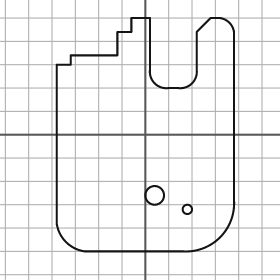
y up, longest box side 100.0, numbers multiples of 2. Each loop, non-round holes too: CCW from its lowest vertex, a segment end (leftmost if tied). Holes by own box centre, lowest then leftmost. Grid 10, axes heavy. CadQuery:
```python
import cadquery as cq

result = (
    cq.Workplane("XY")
    .moveTo(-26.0, -50.0)
    .lineTo(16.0, -50.0)
    .threePointArc((32.0, -44.0), (38.0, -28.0))
    .lineTo(38.0, 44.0)
    .threePointArc((36.0, 48.0), (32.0, 50.0))
    .lineTo(28.0, 50.0)
    .lineTo(22.0, 44.0)
    .lineTo(22.0, 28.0)
    .threePointArc((20.0, 22.0), (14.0, 20.0))
    .lineTo(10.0, 20.0)
    .threePointArc((4.0, 22.0), (2.0, 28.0))
    .lineTo(2.0, 50.0)
    .lineTo(-6.0, 50.0)
    .lineTo(-6.0, 44.0)
    .lineTo(-12.0, 44.0)
    .lineTo(-12.0, 34.0)
    .lineTo(-32.0, 34.0)
    .lineTo(-32.0, 30.0)
    .lineTo(-38.0, 30.0)
    .lineTo(-38.0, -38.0)
    .threePointArc((-34.0, -46.0), (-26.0, -50.0))
    .close()
    .moveTo(18.0, -32.0)
    .circle(2.0)
    .moveTo(4.0, -26.0)
    .circle(4.0)
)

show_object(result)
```